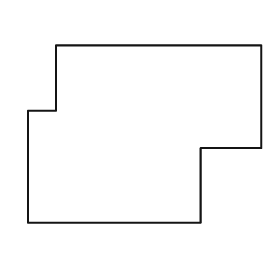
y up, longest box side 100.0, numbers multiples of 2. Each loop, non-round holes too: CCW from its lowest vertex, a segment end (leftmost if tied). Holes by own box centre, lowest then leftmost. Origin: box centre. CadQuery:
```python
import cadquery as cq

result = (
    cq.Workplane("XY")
    .moveTo(-50.0, -38.0)
    .lineTo(24.0, -38.0)
    .lineTo(24.0, -6.0)
    .lineTo(50.0, -6.0)
    .lineTo(50.0, 38.0)
    .lineTo(-38.0, 38.0)
    .lineTo(-38.0, 10.0)
    .lineTo(-50.0, 10.0)
    .close()
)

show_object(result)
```